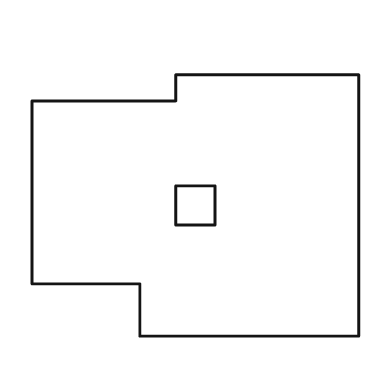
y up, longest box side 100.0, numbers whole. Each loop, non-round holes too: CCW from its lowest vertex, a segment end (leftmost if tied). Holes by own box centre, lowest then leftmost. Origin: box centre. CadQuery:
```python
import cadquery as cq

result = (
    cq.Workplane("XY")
    .moveTo(-17.0, -40.0)
    .lineTo(50.0, -40.0)
    .lineTo(50.0, 40.0)
    .lineTo(-6.0, 40.0)
    .lineTo(-6.0, 32.0)
    .lineTo(-50.0, 32.0)
    .lineTo(-50.0, -24.0)
    .lineTo(-17.0, -24.0)
    .close()
    .moveTo(-6.0, -6.0)
    .lineTo(6.0, -6.0)
    .lineTo(6.0, 6.0)
    .lineTo(-6.0, 6.0)
    .close()
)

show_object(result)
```